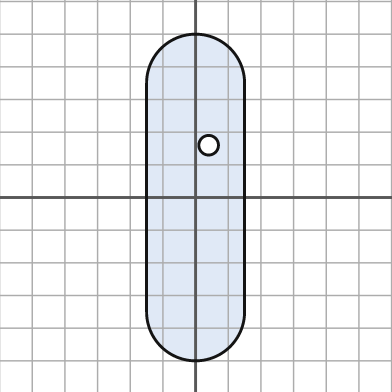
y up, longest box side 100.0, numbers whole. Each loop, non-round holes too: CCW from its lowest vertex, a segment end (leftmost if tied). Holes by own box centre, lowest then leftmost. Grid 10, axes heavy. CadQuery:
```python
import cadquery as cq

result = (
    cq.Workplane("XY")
    .moveTo(-15.0, -35.0)
    .threePointArc((0.0, -50.0), (15.0, -35.0))
    .lineTo(15.0, 35.0)
    .threePointArc((0.0, 50.0), (-15.0, 35.0))
    .close()
    .moveTo(4.0, 16.0)
    .circle(3.0)
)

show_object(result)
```